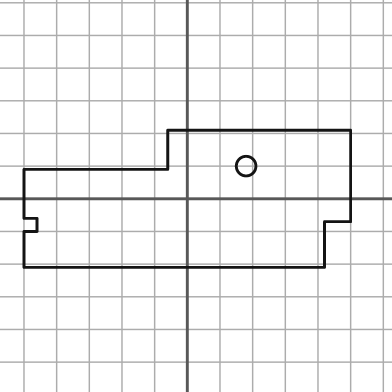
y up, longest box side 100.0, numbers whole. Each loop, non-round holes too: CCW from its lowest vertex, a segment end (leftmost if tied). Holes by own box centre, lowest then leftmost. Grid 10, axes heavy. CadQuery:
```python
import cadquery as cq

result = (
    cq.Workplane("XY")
    .moveTo(-50.0, -21.0)
    .lineTo(42.0, -21.0)
    .lineTo(42.0, -7.0)
    .lineTo(50.0, -7.0)
    .lineTo(50.0, 21.0)
    .lineTo(-6.0, 21.0)
    .lineTo(-6.0, 9.0)
    .lineTo(-50.0, 9.0)
    .lineTo(-50.0, -6.0)
    .lineTo(-46.0, -6.0)
    .lineTo(-46.0, -10.0)
    .lineTo(-50.0, -10.0)
    .close()
    .moveTo(18.0, 10.0)
    .circle(3.0)
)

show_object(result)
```